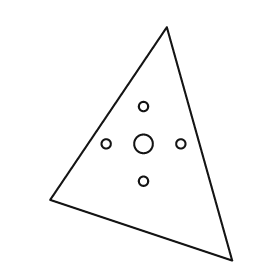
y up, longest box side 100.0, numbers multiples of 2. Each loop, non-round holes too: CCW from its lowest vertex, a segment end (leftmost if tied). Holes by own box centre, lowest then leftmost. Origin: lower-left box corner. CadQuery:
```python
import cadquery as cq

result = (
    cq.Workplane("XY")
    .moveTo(78.0, 0.0)
    .lineTo(50.0, 100.0)
    .lineTo(0.0, 26.0)
    .close()
    .moveTo(40.0, 34.0)
    .circle(2.0)
    .moveTo(24.0, 50.0)
    .circle(2.0)
    .moveTo(40.0, 50.0)
    .circle(4.0)
    .moveTo(56.0, 50.0)
    .circle(2.0)
    .moveTo(40.0, 66.0)
    .circle(2.0)
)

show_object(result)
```